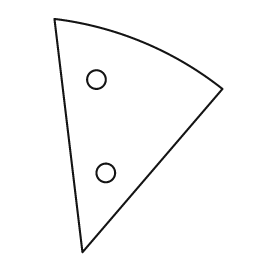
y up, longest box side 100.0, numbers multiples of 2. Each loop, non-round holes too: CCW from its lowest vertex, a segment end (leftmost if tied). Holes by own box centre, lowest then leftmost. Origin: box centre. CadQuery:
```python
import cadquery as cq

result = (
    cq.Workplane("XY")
    .moveTo(-24.0, -50.0)
    .lineTo(36.0, 20.0)
    .threePointArc((2.0, 40.0), (-36.0, 50.0))
    .close()
    .moveTo(-14.0, -16.0)
    .circle(4.0)
    .moveTo(-18.0, 24.0)
    .circle(4.0)
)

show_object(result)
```